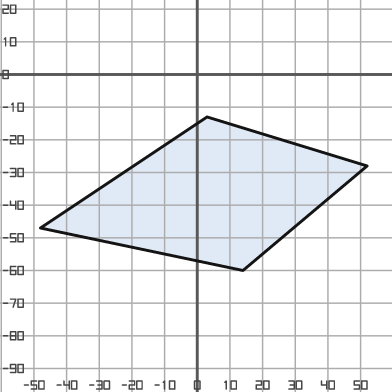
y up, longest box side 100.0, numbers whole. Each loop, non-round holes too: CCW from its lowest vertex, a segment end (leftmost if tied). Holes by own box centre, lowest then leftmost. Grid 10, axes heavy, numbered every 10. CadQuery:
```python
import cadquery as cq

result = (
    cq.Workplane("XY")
    .moveTo(14.0, -60.0)
    .lineTo(52.0, -28.0)
    .lineTo(3.0, -13.0)
    .lineTo(-48.0, -47.0)
    .close()
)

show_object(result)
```